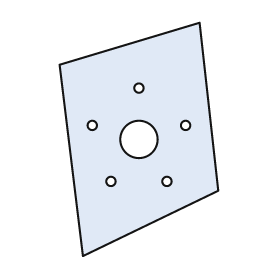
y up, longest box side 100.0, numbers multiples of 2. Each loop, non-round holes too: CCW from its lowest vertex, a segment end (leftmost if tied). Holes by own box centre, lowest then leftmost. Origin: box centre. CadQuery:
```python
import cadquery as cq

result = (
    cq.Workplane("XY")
    .moveTo(-24.0, -50.0)
    .lineTo(34.0, -22.0)
    .lineTo(26.0, 50.0)
    .lineTo(-34.0, 32.0)
    .close()
    .moveTo(-12.0, -18.0)
    .circle(2.0)
    .moveTo(12.0, -18.0)
    .circle(2.0)
    .moveTo(0.0, 0.0)
    .circle(8.0)
    .moveTo(-20.0, 6.0)
    .circle(2.0)
    .moveTo(20.0, 6.0)
    .circle(2.0)
    .moveTo(0.0, 22.0)
    .circle(2.0)
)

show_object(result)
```